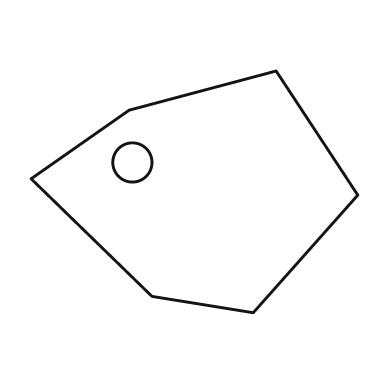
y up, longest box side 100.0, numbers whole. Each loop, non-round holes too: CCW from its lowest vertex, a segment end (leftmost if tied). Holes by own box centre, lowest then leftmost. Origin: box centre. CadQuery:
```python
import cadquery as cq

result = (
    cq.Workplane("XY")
    .moveTo(18.0, -37.0)
    .lineTo(50.0, -1.0)
    .lineTo(25.0, 37.0)
    .lineTo(-20.0, 25.0)
    .lineTo(-50.0, 4.0)
    .lineTo(-13.0, -32.0)
    .close()
    .moveTo(-19.0, 9.0)
    .circle(6.0)
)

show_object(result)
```